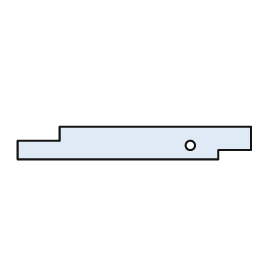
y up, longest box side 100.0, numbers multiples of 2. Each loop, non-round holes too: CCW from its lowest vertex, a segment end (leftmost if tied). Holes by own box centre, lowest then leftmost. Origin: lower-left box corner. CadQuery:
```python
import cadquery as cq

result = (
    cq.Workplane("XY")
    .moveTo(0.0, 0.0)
    .lineTo(86.0, 0.0)
    .lineTo(86.0, 4.0)
    .lineTo(100.0, 4.0)
    .lineTo(100.0, 14.0)
    .lineTo(18.0, 14.0)
    .lineTo(18.0, 8.0)
    .lineTo(0.0, 8.0)
    .close()
    .moveTo(74.0, 6.0)
    .circle(2.0)
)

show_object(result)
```